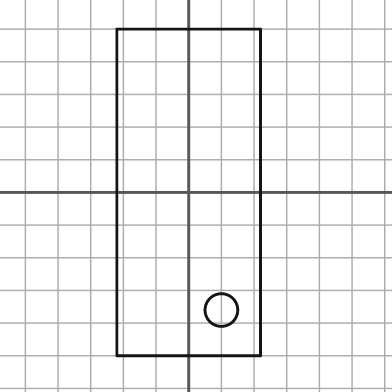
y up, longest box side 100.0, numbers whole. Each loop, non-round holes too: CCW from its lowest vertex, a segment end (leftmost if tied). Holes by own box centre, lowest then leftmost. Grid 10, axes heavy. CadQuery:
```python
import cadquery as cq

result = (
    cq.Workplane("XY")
    .moveTo(-22.0, -50.0)
    .lineTo(22.0, -50.0)
    .lineTo(22.0, 50.0)
    .lineTo(-22.0, 50.0)
    .close()
    .moveTo(10.0, -36.0)
    .circle(5.0)
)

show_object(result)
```